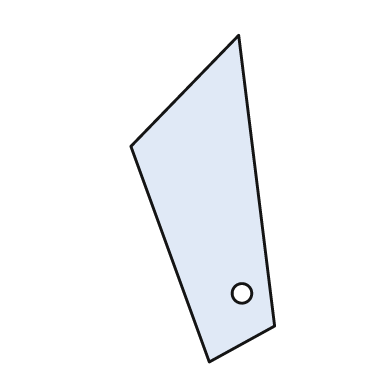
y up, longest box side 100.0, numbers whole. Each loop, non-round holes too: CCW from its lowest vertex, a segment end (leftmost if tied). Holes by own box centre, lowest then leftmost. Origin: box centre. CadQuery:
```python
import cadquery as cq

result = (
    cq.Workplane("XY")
    .moveTo(2.0, -50.0)
    .lineTo(22.0, -39.0)
    .lineTo(11.0, 50.0)
    .lineTo(-22.0, 16.0)
    .close()
    .moveTo(12.0, -29.0)
    .circle(3.0)
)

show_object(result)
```